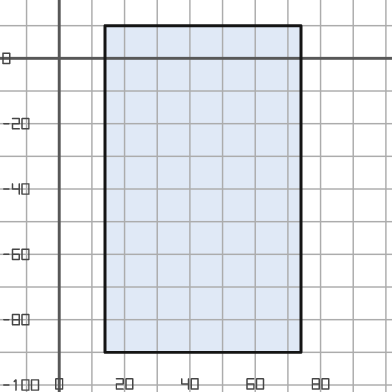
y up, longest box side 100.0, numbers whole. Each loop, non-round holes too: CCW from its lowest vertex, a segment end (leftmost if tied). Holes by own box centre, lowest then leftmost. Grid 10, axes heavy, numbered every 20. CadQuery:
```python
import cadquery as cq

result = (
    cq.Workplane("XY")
    .moveTo(14.0, -90.0)
    .lineTo(74.0, -90.0)
    .lineTo(74.0, 10.0)
    .lineTo(14.0, 10.0)
    .close()
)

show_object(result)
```